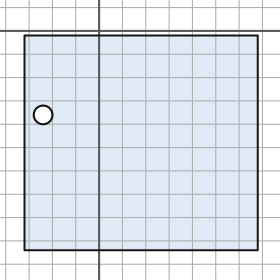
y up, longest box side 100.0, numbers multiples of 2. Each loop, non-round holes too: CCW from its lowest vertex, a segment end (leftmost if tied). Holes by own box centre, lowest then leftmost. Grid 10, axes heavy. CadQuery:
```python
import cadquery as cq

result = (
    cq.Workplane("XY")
    .moveTo(-32.0, -94.0)
    .lineTo(68.0, -94.0)
    .lineTo(68.0, -2.0)
    .lineTo(-32.0, -2.0)
    .close()
    .moveTo(-24.0, -36.0)
    .circle(4.0)
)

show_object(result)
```